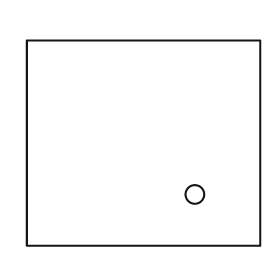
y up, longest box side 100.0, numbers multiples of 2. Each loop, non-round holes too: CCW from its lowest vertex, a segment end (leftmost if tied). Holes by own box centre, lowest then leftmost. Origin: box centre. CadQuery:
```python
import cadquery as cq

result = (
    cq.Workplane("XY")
    .moveTo(-50.0, -44.0)
    .lineTo(50.0, -44.0)
    .lineTo(50.0, 44.0)
    .lineTo(-50.0, 44.0)
    .close()
    .moveTo(22.0, -22.0)
    .circle(4.0)
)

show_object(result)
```